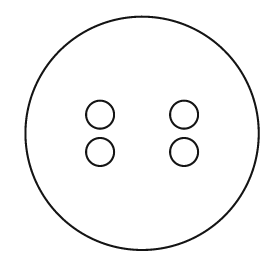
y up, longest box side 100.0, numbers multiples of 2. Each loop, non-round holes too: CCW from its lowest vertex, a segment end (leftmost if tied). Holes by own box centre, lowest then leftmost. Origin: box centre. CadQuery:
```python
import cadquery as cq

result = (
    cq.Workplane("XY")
    .moveTo(0.0, 0.0)
    .circle(50.0)
    .moveTo(-18.0, -8.0)
    .circle(6.0)
    .moveTo(18.0, -8.0)
    .circle(6.0)
    .moveTo(-18.0, 8.0)
    .circle(6.0)
    .moveTo(18.0, 8.0)
    .circle(6.0)
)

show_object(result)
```